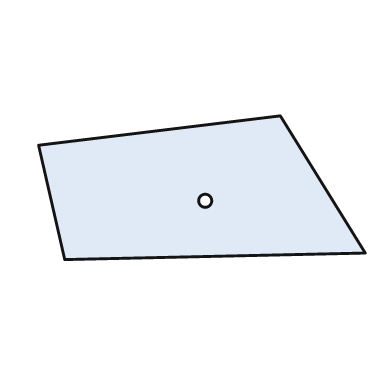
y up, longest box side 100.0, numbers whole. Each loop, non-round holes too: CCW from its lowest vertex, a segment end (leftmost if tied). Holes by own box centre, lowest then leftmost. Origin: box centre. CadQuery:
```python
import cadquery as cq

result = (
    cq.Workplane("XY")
    .moveTo(-42.0, -22.0)
    .lineTo(50.0, -20.0)
    .lineTo(24.0, 22.0)
    .lineTo(-50.0, 13.0)
    .close()
    .moveTo(1.0, -4.0)
    .circle(2.0)
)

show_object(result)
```